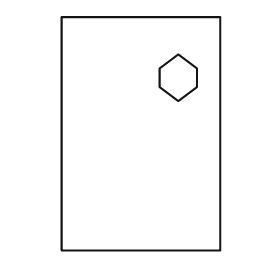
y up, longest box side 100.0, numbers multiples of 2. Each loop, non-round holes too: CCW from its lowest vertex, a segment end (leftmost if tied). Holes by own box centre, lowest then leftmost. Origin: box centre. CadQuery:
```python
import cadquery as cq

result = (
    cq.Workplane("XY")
    .moveTo(-34.0, -50.0)
    .lineTo(34.0, -50.0)
    .lineTo(34.0, 50.0)
    .lineTo(-34.0, 50.0)
    .close()
    .moveTo(16.0, 14.0)
    .lineTo(24.0, 20.0)
    .lineTo(24.0, 28.0)
    .lineTo(16.0, 34.0)
    .lineTo(8.0, 28.0)
    .lineTo(8.0, 20.0)
    .close()
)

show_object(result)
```